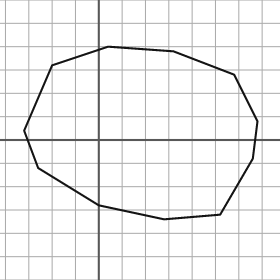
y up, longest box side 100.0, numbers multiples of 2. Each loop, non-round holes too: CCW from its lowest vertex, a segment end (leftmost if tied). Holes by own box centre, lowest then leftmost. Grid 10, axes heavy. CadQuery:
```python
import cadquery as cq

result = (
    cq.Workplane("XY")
    .moveTo(28.0, -34.0)
    .lineTo(52.0, -32.0)
    .lineTo(66.0, -8.0)
    .lineTo(68.0, 8.0)
    .lineTo(58.0, 28.0)
    .lineTo(32.0, 38.0)
    .lineTo(4.0, 40.0)
    .lineTo(-20.0, 32.0)
    .lineTo(-32.0, 4.0)
    .lineTo(-26.0, -12.0)
    .lineTo(0.0, -28.0)
    .close()
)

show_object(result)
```